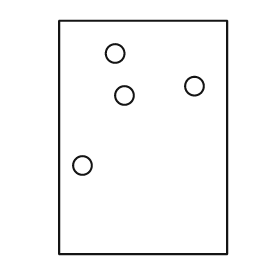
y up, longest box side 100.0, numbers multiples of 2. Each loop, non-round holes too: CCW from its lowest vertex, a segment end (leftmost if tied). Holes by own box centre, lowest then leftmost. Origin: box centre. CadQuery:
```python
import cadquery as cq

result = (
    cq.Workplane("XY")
    .moveTo(-36.0, -50.0)
    .lineTo(36.0, -50.0)
    .lineTo(36.0, 50.0)
    .lineTo(-36.0, 50.0)
    .close()
    .moveTo(-26.0, -12.0)
    .circle(4.0)
    .moveTo(-8.0, 18.0)
    .circle(4.0)
    .moveTo(22.0, 22.0)
    .circle(4.0)
    .moveTo(-12.0, 36.0)
    .circle(4.0)
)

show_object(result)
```